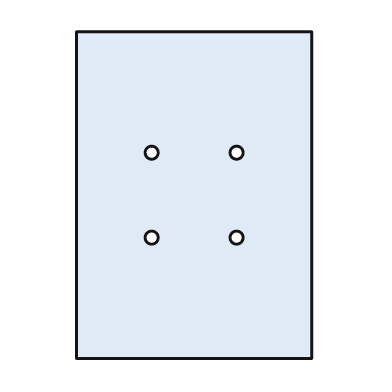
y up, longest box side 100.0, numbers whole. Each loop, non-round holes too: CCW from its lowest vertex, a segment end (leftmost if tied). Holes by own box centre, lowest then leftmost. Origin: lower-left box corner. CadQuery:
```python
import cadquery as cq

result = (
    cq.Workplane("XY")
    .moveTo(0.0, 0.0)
    .lineTo(72.0, 0.0)
    .lineTo(72.0, 100.0)
    .lineTo(0.0, 100.0)
    .close()
    .moveTo(23.0, 37.0)
    .circle(2.0)
    .moveTo(49.0, 37.0)
    .circle(2.0)
    .moveTo(23.0, 63.0)
    .circle(2.0)
    .moveTo(49.0, 63.0)
    .circle(2.0)
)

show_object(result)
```